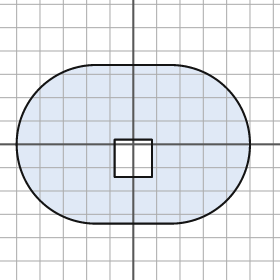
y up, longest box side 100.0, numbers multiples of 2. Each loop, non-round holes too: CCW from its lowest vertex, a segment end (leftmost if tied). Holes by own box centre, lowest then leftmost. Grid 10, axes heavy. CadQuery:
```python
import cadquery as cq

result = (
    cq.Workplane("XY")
    .moveTo(-16.0, -34.0)
    .lineTo(16.0, -34.0)
    .threePointArc((50.0, 0.0), (16.0, 34.0))
    .lineTo(-16.0, 34.0)
    .threePointArc((-50.0, 0.0), (-16.0, -34.0))
    .close()
    .moveTo(-8.0, -14.0)
    .lineTo(8.0, -14.0)
    .lineTo(8.0, 2.0)
    .lineTo(-8.0, 2.0)
    .close()
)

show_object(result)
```